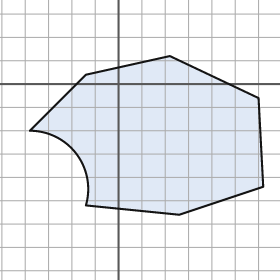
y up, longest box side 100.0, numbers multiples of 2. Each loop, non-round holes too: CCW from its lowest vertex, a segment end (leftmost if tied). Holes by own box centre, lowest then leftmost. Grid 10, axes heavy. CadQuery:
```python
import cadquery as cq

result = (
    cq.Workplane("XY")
    .moveTo(26.0, -56.0)
    .lineTo(62.0, -44.0)
    .lineTo(60.0, -6.0)
    .lineTo(22.0, 12.0)
    .lineTo(-14.0, 4.0)
    .lineTo(-38.0, -20.0)
    .threePointArc((-18.0, -30.0), (-14.0, -52.0))
    .close()
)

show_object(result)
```